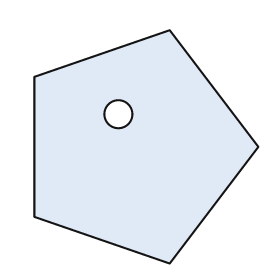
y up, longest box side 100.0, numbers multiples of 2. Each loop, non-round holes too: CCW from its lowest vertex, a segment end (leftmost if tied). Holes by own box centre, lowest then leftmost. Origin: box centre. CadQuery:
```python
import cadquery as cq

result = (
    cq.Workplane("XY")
    .moveTo(10.0, -50.0)
    .lineTo(48.0, 0.0)
    .lineTo(10.0, 50.0)
    .lineTo(-48.0, 30.0)
    .lineTo(-48.0, -30.0)
    .close()
    .moveTo(-12.0, 14.0)
    .circle(6.0)
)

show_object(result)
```